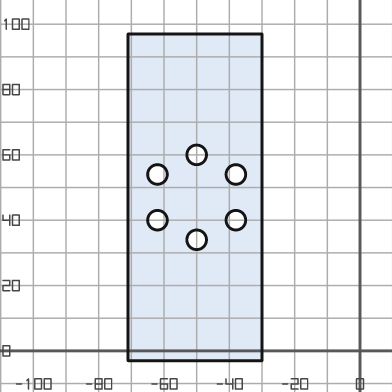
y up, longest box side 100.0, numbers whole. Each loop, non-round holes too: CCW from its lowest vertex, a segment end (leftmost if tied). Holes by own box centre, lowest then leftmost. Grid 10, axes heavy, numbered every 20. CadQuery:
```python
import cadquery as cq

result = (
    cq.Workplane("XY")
    .moveTo(-71.0, -3.0)
    .lineTo(-30.0, -3.0)
    .lineTo(-30.0, 97.0)
    .lineTo(-71.0, 97.0)
    .close()
    .moveTo(-50.0, 34.0)
    .circle(3.0)
    .moveTo(-62.0, 40.0)
    .circle(3.0)
    .moveTo(-38.0, 40.0)
    .circle(3.0)
    .moveTo(-62.0, 54.0)
    .circle(3.0)
    .moveTo(-38.0, 54.0)
    .circle(3.0)
    .moveTo(-50.0, 60.0)
    .circle(3.0)
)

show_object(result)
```